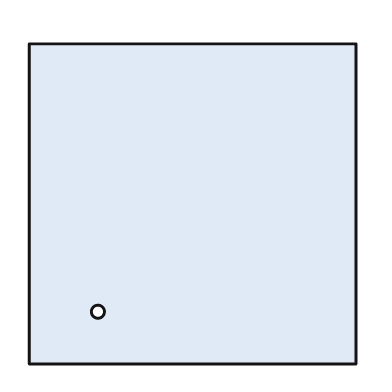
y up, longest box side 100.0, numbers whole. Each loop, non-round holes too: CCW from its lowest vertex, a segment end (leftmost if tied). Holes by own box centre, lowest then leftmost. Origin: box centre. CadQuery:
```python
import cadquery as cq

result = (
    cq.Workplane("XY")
    .moveTo(-50.0, -49.0)
    .lineTo(50.0, -49.0)
    .lineTo(50.0, 49.0)
    .lineTo(-50.0, 49.0)
    .close()
    .moveTo(-29.0, -33.0)
    .circle(2.0)
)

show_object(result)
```